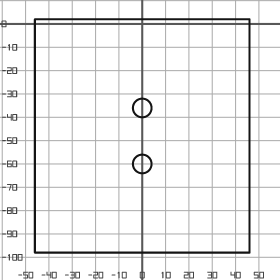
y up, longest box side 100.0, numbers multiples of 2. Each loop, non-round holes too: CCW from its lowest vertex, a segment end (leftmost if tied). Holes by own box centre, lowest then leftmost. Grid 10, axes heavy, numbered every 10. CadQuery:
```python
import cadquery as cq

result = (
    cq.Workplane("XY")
    .moveTo(-46.0, -98.0)
    .lineTo(46.0, -98.0)
    .lineTo(46.0, 2.0)
    .lineTo(-46.0, 2.0)
    .close()
    .moveTo(0.0, -60.0)
    .circle(4.0)
    .moveTo(0.0, -36.0)
    .circle(4.0)
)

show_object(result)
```